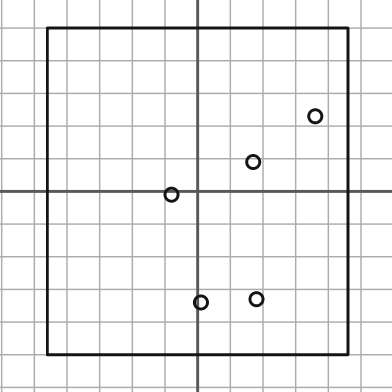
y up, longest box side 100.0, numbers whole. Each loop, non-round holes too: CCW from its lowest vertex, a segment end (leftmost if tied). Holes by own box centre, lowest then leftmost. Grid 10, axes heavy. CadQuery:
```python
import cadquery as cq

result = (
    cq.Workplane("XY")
    .moveTo(-46.0, -50.0)
    .lineTo(46.0, -50.0)
    .lineTo(46.0, 50.0)
    .lineTo(-46.0, 50.0)
    .close()
    .moveTo(1.0, -34.0)
    .circle(2.0)
    .moveTo(18.0, -33.0)
    .circle(2.0)
    .moveTo(-8.0, -1.0)
    .circle(2.0)
    .moveTo(17.0, 9.0)
    .circle(2.0)
    .moveTo(36.0, 23.0)
    .circle(2.0)
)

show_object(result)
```